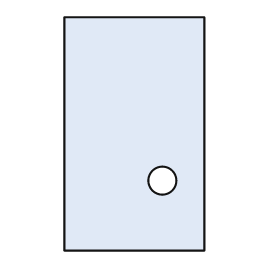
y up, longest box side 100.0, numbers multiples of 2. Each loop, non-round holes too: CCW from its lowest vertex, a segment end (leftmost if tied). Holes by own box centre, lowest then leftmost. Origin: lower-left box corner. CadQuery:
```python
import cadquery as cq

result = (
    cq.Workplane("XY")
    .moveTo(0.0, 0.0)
    .lineTo(60.0, 0.0)
    .lineTo(60.0, 100.0)
    .lineTo(0.0, 100.0)
    .close()
    .moveTo(42.0, 30.0)
    .circle(6.0)
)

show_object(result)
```